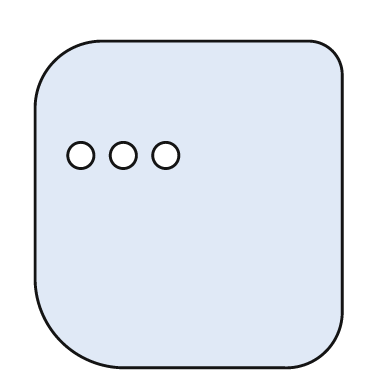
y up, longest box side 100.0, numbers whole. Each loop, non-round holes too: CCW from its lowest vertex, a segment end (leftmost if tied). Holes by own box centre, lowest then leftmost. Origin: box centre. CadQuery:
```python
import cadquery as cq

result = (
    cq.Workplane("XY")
    .moveTo(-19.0, -50.0)
    .lineTo(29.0, -50.0)
    .threePointArc((42.0, -45.0), (47.0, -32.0))
    .lineTo(47.0, 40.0)
    .threePointArc((44.0, 47.0), (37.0, 50.0))
    .lineTo(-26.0, 50.0)
    .threePointArc((-41.0, 44.0), (-47.0, 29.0))
    .lineTo(-47.0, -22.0)
    .threePointArc((-39.0, -42.0), (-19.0, -50.0))
    .close()
    .moveTo(-33.0, 15.0)
    .circle(4.0)
    .moveTo(-20.0, 15.0)
    .circle(4.0)
    .moveTo(-7.0, 15.0)
    .circle(4.0)
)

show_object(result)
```